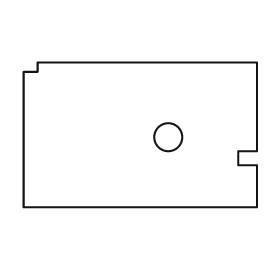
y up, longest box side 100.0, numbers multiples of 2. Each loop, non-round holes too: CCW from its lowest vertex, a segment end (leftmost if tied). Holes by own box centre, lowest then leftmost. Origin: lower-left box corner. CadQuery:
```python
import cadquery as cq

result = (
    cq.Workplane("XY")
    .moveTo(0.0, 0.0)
    .lineTo(100.0, 0.0)
    .lineTo(100.0, 18.0)
    .lineTo(92.0, 18.0)
    .lineTo(92.0, 24.0)
    .lineTo(100.0, 24.0)
    .lineTo(100.0, 62.0)
    .lineTo(6.0, 62.0)
    .lineTo(6.0, 58.0)
    .lineTo(0.0, 58.0)
    .close()
    .moveTo(62.0, 30.0)
    .circle(6.0)
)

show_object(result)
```